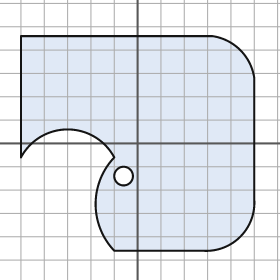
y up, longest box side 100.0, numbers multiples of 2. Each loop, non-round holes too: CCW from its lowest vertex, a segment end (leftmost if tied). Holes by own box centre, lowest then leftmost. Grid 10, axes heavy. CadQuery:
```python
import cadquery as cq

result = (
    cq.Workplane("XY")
    .moveTo(-10.0, -46.0)
    .lineTo(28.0, -46.0)
    .threePointArc((44.0, -40.0), (50.0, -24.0))
    .lineTo(50.0, 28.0)
    .threePointArc((44.0, 40.0), (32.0, 46.0))
    .lineTo(-50.0, 46.0)
    .lineTo(-50.0, -6.0)
    .threePointArc((-30.0, 6.0), (-10.0, -6.0))
    .threePointArc((-18.0, -26.0), (-10.0, -46.0))
    .close()
    .moveTo(-6.0, -14.0)
    .circle(4.0)
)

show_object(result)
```